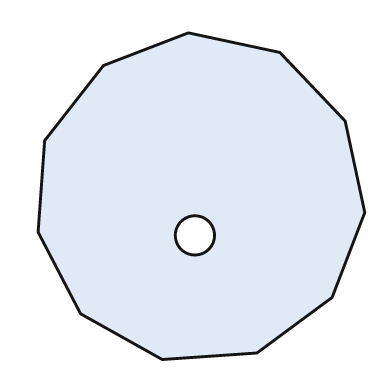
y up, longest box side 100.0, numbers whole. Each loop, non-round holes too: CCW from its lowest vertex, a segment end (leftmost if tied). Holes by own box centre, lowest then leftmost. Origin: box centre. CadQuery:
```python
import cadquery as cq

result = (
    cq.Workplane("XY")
    .moveTo(-12.0, -50.0)
    .lineTo(17.0, -48.0)
    .lineTo(40.0, -31.0)
    .lineTo(50.0, -5.0)
    .lineTo(44.0, 23.0)
    .lineTo(24.0, 44.0)
    .lineTo(-4.0, 50.0)
    .lineTo(-30.0, 40.0)
    .lineTo(-48.0, 17.0)
    .lineTo(-50.0, -11.0)
    .lineTo(-37.0, -36.0)
    .close()
    .moveTo(-2.0, -12.0)
    .circle(6.0)
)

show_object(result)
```